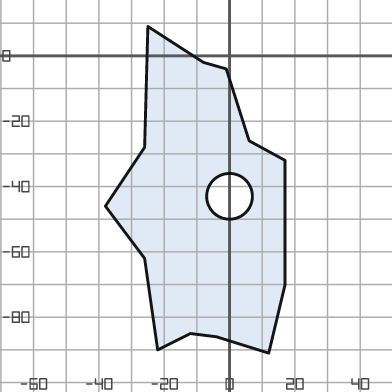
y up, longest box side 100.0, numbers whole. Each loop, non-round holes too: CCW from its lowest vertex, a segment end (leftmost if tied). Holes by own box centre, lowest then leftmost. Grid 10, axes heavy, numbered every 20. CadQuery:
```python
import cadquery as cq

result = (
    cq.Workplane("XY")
    .moveTo(12.0, -91.0)
    .lineTo(17.0, -70.0)
    .lineTo(17.0, -32.0)
    .lineTo(6.0, -26.0)
    .lineTo(-1.0, -4.0)
    .lineTo(-8.0, -2.0)
    .lineTo(-25.0, 9.0)
    .lineTo(-26.0, -28.0)
    .lineTo(-38.0, -46.0)
    .lineTo(-26.0, -62.0)
    .lineTo(-22.0, -90.0)
    .lineTo(-12.0, -85.0)
    .lineTo(-4.0, -86.0)
    .close()
    .moveTo(0.0, -43.0)
    .circle(7.0)
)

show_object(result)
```